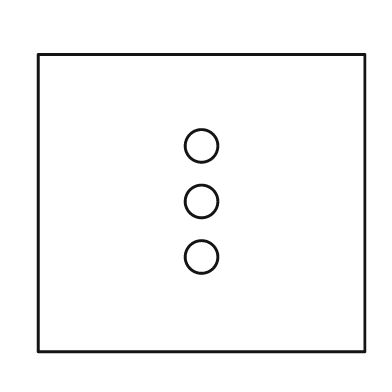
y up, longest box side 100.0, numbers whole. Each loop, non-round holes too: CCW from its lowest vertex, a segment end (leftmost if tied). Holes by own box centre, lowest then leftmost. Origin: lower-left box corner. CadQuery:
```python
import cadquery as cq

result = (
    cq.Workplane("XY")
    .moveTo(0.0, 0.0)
    .lineTo(100.0, 0.0)
    .lineTo(100.0, 91.0)
    .lineTo(0.0, 91.0)
    .close()
    .moveTo(50.0, 29.0)
    .circle(5.0)
    .moveTo(50.0, 46.0)
    .circle(5.0)
    .moveTo(50.0, 63.0)
    .circle(5.0)
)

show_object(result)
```